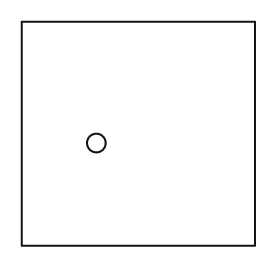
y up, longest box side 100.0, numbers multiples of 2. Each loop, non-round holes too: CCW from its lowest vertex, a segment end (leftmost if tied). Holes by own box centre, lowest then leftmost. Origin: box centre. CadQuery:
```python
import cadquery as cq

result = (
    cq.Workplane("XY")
    .moveTo(-50.0, -48.0)
    .lineTo(50.0, -48.0)
    .lineTo(50.0, 48.0)
    .lineTo(-50.0, 48.0)
    .close()
    .moveTo(-18.0, -4.0)
    .circle(4.0)
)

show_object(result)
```